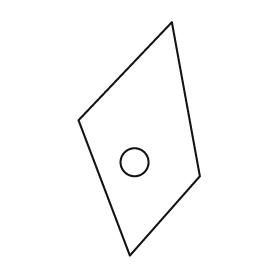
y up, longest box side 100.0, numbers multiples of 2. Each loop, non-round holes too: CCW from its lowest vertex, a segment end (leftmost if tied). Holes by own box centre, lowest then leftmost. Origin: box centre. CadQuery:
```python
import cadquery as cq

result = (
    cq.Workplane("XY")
    .moveTo(-4.0, -50.0)
    .lineTo(26.0, -16.0)
    .lineTo(14.0, 50.0)
    .lineTo(-26.0, 8.0)
    .close()
    .moveTo(-2.0, -10.0)
    .circle(6.0)
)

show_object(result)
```